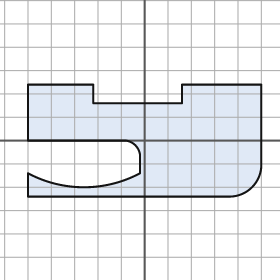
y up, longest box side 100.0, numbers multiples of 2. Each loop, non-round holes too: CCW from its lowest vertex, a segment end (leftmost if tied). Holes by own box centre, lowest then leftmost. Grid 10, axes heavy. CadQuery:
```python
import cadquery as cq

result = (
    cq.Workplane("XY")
    .moveTo(-50.0, -24.0)
    .lineTo(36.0, -24.0)
    .threePointArc((46.0, -20.0), (50.0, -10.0))
    .lineTo(50.0, 24.0)
    .lineTo(16.0, 24.0)
    .lineTo(16.0, 16.0)
    .lineTo(-22.0, 16.0)
    .lineTo(-22.0, 24.0)
    .lineTo(-50.0, 24.0)
    .lineTo(-50.0, 0.0)
    .lineTo(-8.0, 0.0)
    .threePointArc((-4.0, -2.0), (-2.0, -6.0))
    .lineTo(-2.0, -14.0)
    .threePointArc((-26.0, -20.0), (-50.0, -14.0))
    .close()
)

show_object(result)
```